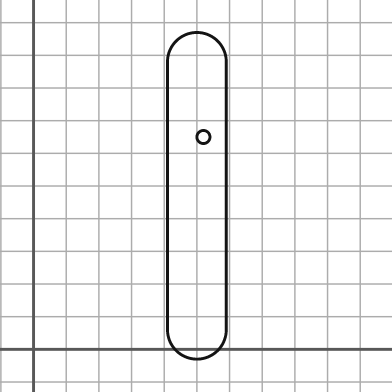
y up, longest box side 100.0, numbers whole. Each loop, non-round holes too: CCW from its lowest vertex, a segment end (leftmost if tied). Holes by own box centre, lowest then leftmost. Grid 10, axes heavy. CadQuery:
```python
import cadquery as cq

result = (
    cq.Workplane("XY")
    .moveTo(41.0, 6.0)
    .threePointArc((50.0, -3.0), (59.0, 6.0))
    .lineTo(59.0, 88.0)
    .threePointArc((50.0, 97.0), (41.0, 88.0))
    .close()
    .moveTo(52.0, 65.0)
    .circle(2.0)
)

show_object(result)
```